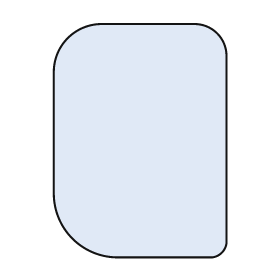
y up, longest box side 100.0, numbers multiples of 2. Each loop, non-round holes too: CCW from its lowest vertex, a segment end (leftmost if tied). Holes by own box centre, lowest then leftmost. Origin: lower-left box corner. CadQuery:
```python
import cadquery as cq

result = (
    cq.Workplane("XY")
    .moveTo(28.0, 0.0)
    .lineTo(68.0, 0.0)
    .threePointArc((72.0, 2.0), (74.0, 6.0))
    .lineTo(74.0, 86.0)
    .threePointArc((70.0, 96.0), (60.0, 100.0))
    .lineTo(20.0, 100.0)
    .threePointArc((6.0, 94.0), (0.0, 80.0))
    .lineTo(0.0, 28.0)
    .threePointArc((8.0, 8.0), (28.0, 0.0))
    .close()
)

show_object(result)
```